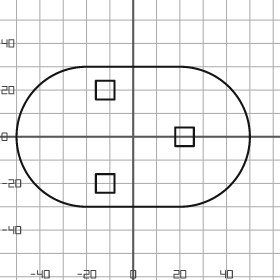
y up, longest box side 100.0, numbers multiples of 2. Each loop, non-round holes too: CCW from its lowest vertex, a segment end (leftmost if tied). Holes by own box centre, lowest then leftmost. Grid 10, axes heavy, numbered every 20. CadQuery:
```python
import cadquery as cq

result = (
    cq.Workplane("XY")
    .moveTo(-20.0, -30.0)
    .lineTo(20.0, -30.0)
    .threePointArc((50.0, 0.0), (20.0, 30.0))
    .lineTo(-20.0, 30.0)
    .threePointArc((-50.0, 0.0), (-20.0, -30.0))
    .close()
    .moveTo(-16.0, -24.0)
    .lineTo(-8.0, -24.0)
    .lineTo(-8.0, -16.0)
    .lineTo(-16.0, -16.0)
    .close()
    .moveTo(18.0, -4.0)
    .lineTo(26.0, -4.0)
    .lineTo(26.0, 4.0)
    .lineTo(18.0, 4.0)
    .close()
    .moveTo(-16.0, 16.0)
    .lineTo(-8.0, 16.0)
    .lineTo(-8.0, 24.0)
    .lineTo(-16.0, 24.0)
    .close()
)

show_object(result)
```